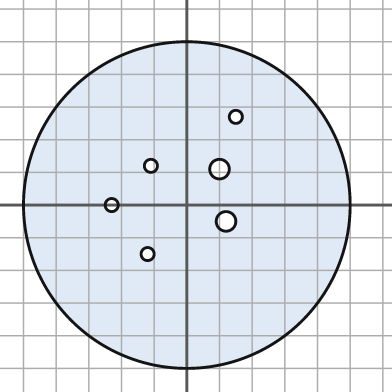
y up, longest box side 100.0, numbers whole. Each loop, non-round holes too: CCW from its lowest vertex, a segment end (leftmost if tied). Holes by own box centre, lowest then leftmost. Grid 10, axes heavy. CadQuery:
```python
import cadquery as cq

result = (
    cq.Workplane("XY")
    .moveTo(0.0, 0.0)
    .circle(50.0)
    .moveTo(-12.0, -15.0)
    .circle(2.0)
    .moveTo(12.0, -5.0)
    .circle(3.0)
    .moveTo(-23.0, 0.0)
    .circle(2.0)
    .moveTo(10.0, 11.0)
    .circle(3.0)
    .moveTo(-11.0, 12.0)
    .circle(2.0)
    .moveTo(15.0, 27.0)
    .circle(2.0)
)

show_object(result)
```